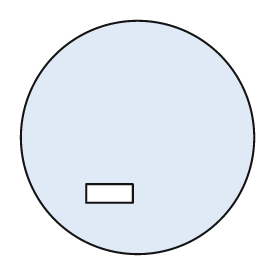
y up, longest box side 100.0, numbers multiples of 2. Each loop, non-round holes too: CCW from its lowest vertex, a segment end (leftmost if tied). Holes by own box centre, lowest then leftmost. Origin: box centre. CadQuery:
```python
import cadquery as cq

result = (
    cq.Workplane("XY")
    .moveTo(0.0, 0.0)
    .circle(50.0)
    .moveTo(-22.0, -28.0)
    .lineTo(-2.0, -28.0)
    .lineTo(-2.0, -20.0)
    .lineTo(-22.0, -20.0)
    .close()
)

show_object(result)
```